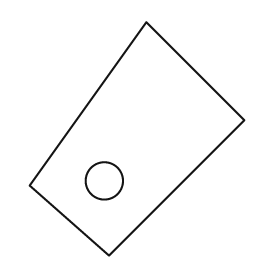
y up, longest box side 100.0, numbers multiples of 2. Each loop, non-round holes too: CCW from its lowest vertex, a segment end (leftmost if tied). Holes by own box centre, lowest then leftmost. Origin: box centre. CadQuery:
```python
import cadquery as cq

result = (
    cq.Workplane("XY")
    .moveTo(-12.0, -50.0)
    .lineTo(46.0, 8.0)
    .lineTo(4.0, 50.0)
    .lineTo(-46.0, -20.0)
    .close()
    .moveTo(-14.0, -18.0)
    .circle(8.0)
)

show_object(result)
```